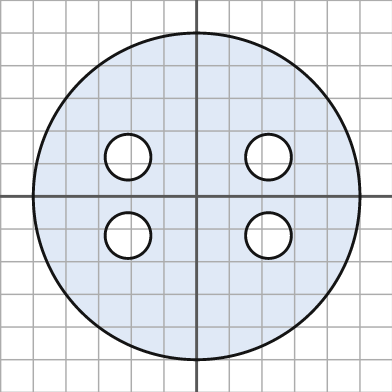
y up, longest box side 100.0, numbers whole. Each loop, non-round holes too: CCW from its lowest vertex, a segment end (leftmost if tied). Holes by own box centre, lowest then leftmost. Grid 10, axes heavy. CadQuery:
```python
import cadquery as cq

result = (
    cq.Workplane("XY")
    .moveTo(0.0, 0.0)
    .circle(50.0)
    .moveTo(-21.0, -12.0)
    .circle(7.0)
    .moveTo(22.0, -12.0)
    .circle(7.0)
    .moveTo(-21.0, 12.0)
    .circle(7.0)
    .moveTo(22.0, 12.0)
    .circle(7.0)
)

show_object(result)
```